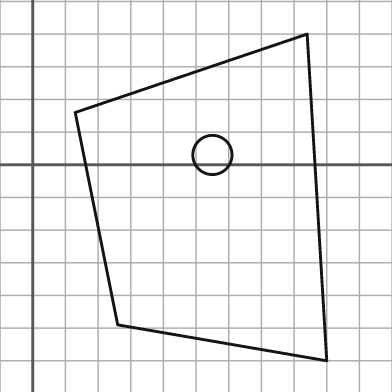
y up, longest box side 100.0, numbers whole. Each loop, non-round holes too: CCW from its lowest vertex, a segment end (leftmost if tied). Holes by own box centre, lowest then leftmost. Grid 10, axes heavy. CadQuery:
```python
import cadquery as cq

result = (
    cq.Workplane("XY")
    .moveTo(90.0, -60.0)
    .lineTo(84.0, 40.0)
    .lineTo(13.0, 16.0)
    .lineTo(26.0, -49.0)
    .close()
    .moveTo(55.0, 3.0)
    .circle(6.0)
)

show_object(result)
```